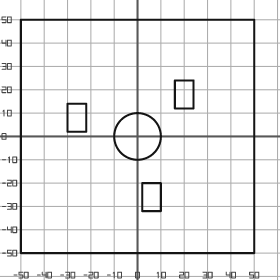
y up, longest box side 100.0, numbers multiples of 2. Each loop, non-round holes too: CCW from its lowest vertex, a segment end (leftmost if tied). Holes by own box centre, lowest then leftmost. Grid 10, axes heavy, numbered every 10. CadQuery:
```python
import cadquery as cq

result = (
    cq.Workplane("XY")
    .moveTo(-50.0, -50.0)
    .lineTo(50.0, -50.0)
    .lineTo(50.0, 50.0)
    .lineTo(-50.0, 50.0)
    .close()
    .moveTo(2.0, -32.0)
    .lineTo(10.0, -32.0)
    .lineTo(10.0, -20.0)
    .lineTo(2.0, -20.0)
    .close()
    .moveTo(0.0, 0.0)
    .circle(10.0)
    .moveTo(-30.0, 2.0)
    .lineTo(-22.0, 2.0)
    .lineTo(-22.0, 14.0)
    .lineTo(-30.0, 14.0)
    .close()
    .moveTo(16.0, 12.0)
    .lineTo(24.0, 12.0)
    .lineTo(24.0, 24.0)
    .lineTo(16.0, 24.0)
    .close()
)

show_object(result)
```